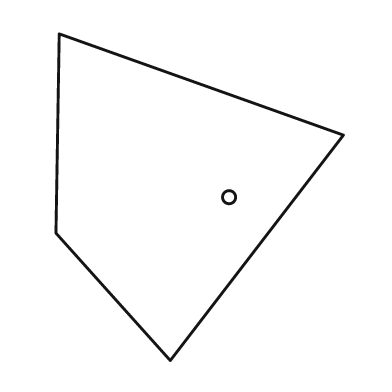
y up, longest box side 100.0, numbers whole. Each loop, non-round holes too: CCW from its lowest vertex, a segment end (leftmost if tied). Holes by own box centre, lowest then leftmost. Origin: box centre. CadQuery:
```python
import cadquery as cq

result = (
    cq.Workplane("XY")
    .moveTo(-9.0, -50.0)
    .lineTo(44.0, 19.0)
    .lineTo(-43.0, 50.0)
    .lineTo(-44.0, -11.0)
    .close()
    .moveTo(9.0, 0.0)
    .circle(2.0)
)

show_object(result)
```